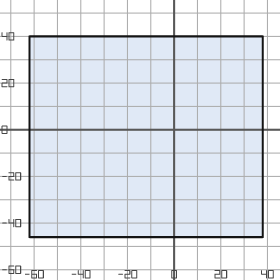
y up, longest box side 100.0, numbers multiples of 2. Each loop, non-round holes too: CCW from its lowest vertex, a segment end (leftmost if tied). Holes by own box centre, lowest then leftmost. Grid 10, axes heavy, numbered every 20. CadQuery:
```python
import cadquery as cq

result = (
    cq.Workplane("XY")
    .moveTo(-62.0, -46.0)
    .lineTo(38.0, -46.0)
    .lineTo(38.0, 40.0)
    .lineTo(-62.0, 40.0)
    .close()
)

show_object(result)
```